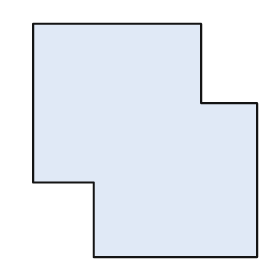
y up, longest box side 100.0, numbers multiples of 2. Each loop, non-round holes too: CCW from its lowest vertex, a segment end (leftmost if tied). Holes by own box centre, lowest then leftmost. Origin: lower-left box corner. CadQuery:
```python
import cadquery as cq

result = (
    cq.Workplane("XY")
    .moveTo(26.0, 0.0)
    .lineTo(96.0, 0.0)
    .lineTo(96.0, 66.0)
    .lineTo(72.0, 66.0)
    .lineTo(72.0, 100.0)
    .lineTo(0.0, 100.0)
    .lineTo(0.0, 32.0)
    .lineTo(26.0, 32.0)
    .close()
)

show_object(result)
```